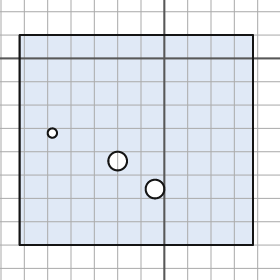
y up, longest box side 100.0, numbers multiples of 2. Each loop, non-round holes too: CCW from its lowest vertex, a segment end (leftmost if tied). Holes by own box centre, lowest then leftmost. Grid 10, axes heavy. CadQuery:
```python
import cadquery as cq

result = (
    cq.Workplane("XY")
    .moveTo(-62.0, -80.0)
    .lineTo(38.0, -80.0)
    .lineTo(38.0, 10.0)
    .lineTo(-62.0, 10.0)
    .close()
    .moveTo(-4.0, -56.0)
    .circle(4.0)
    .moveTo(-20.0, -44.0)
    .circle(4.0)
    .moveTo(-48.0, -32.0)
    .circle(2.0)
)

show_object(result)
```